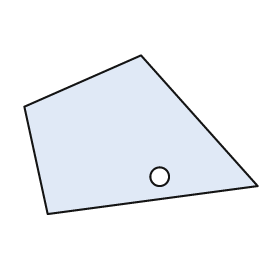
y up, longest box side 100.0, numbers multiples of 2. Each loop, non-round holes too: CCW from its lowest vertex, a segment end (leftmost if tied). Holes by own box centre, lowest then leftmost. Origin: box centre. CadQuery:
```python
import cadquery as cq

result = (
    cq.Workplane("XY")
    .moveTo(-40.0, -34.0)
    .lineTo(50.0, -22.0)
    .lineTo(0.0, 34.0)
    .lineTo(-50.0, 12.0)
    .close()
    .moveTo(8.0, -18.0)
    .circle(4.0)
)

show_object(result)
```